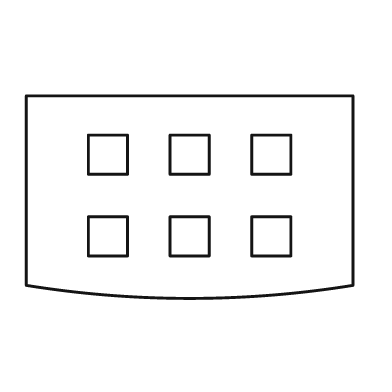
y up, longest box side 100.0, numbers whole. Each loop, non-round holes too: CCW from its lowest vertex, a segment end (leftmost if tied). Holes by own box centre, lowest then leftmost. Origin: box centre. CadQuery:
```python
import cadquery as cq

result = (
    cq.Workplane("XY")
    .moveTo(-50.0, -27.0)
    .threePointArc((0.0, -31.0), (50.0, -27.0))
    .lineTo(50.0, 31.0)
    .lineTo(-50.0, 31.0)
    .close()
    .moveTo(-31.0, -18.0)
    .lineTo(-19.0, -18.0)
    .lineTo(-19.0, -6.0)
    .lineTo(-31.0, -6.0)
    .close()
    .moveTo(-6.0, -18.0)
    .lineTo(6.0, -18.0)
    .lineTo(6.0, -6.0)
    .lineTo(-6.0, -6.0)
    .close()
    .moveTo(19.0, -18.0)
    .lineTo(31.0, -18.0)
    .lineTo(31.0, -6.0)
    .lineTo(19.0, -6.0)
    .close()
    .moveTo(-31.0, 7.0)
    .lineTo(-19.0, 7.0)
    .lineTo(-19.0, 19.0)
    .lineTo(-31.0, 19.0)
    .close()
    .moveTo(-6.0, 7.0)
    .lineTo(6.0, 7.0)
    .lineTo(6.0, 19.0)
    .lineTo(-6.0, 19.0)
    .close()
    .moveTo(19.0, 7.0)
    .lineTo(31.0, 7.0)
    .lineTo(31.0, 19.0)
    .lineTo(19.0, 19.0)
    .close()
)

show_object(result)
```